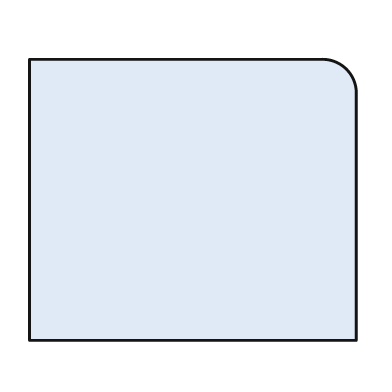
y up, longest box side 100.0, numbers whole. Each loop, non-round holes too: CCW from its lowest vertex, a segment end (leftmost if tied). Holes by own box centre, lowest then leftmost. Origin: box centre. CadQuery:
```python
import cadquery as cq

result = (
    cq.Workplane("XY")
    .moveTo(-50.0, -43.0)
    .lineTo(50.0, -43.0)
    .lineTo(50.0, 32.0)
    .threePointArc((47.0, 40.0), (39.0, 43.0))
    .lineTo(-50.0, 43.0)
    .close()
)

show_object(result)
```